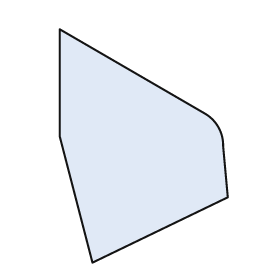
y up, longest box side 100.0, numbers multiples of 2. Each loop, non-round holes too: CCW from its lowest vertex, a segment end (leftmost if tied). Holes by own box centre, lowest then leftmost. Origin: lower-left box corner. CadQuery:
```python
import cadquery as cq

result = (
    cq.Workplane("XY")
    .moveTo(14.0, 0.0)
    .lineTo(72.0, 28.0)
    .lineTo(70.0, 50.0)
    .threePointArc((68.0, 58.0), (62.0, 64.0))
    .lineTo(0.0, 100.0)
    .lineTo(0.0, 54.0)
    .close()
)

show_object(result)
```